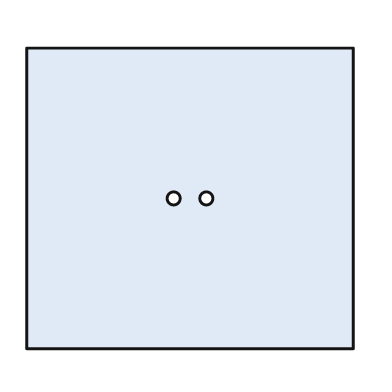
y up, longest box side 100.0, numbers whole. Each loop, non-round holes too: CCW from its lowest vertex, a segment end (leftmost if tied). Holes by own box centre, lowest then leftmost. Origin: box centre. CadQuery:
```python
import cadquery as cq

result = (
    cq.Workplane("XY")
    .moveTo(-50.0, -46.0)
    .lineTo(50.0, -46.0)
    .lineTo(50.0, 46.0)
    .lineTo(-50.0, 46.0)
    .close()
    .moveTo(-5.0, 0.0)
    .circle(2.0)
    .moveTo(5.0, 0.0)
    .circle(2.0)
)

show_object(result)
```